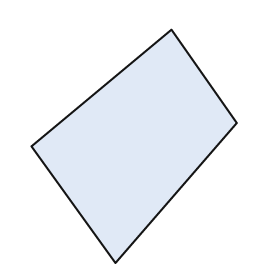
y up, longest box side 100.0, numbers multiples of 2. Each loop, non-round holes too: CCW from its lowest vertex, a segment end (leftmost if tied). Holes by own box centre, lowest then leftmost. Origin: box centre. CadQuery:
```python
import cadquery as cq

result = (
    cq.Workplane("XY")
    .moveTo(-8.0, -50.0)
    .lineTo(44.0, 10.0)
    .lineTo(16.0, 50.0)
    .lineTo(-44.0, 0.0)
    .close()
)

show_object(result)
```